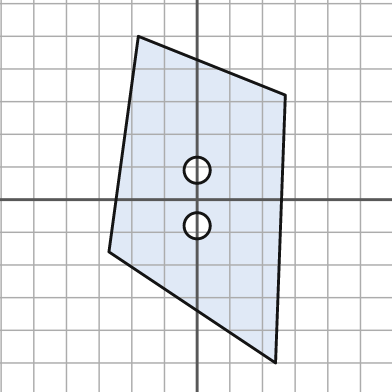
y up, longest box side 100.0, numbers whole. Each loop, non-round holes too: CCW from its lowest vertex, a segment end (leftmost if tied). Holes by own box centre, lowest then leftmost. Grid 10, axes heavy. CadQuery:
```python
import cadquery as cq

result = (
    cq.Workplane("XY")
    .moveTo(24.0, -50.0)
    .lineTo(27.0, 32.0)
    .lineTo(-18.0, 50.0)
    .lineTo(-27.0, -16.0)
    .close()
    .moveTo(0.0, -8.0)
    .circle(4.0)
    .moveTo(0.0, 9.0)
    .circle(4.0)
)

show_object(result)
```